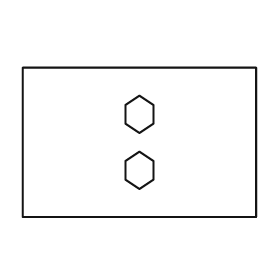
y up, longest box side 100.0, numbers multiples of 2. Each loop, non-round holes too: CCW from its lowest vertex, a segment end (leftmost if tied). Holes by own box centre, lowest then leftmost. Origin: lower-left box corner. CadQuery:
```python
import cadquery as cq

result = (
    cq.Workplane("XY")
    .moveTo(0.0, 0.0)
    .lineTo(100.0, 0.0)
    .lineTo(100.0, 64.0)
    .lineTo(0.0, 64.0)
    .close()
    .moveTo(50.0, 12.0)
    .lineTo(56.0, 16.0)
    .lineTo(56.0, 24.0)
    .lineTo(50.0, 28.0)
    .lineTo(44.0, 24.0)
    .lineTo(44.0, 16.0)
    .close()
    .moveTo(50.0, 36.0)
    .lineTo(56.0, 40.0)
    .lineTo(56.0, 48.0)
    .lineTo(50.0, 52.0)
    .lineTo(44.0, 48.0)
    .lineTo(44.0, 40.0)
    .close()
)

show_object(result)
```